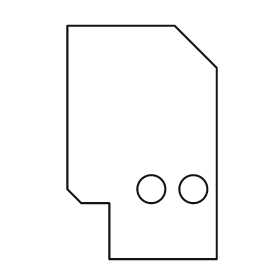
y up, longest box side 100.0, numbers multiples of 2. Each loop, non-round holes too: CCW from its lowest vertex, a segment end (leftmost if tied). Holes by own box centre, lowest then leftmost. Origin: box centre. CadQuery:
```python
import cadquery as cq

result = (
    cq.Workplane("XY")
    .moveTo(-14.0, -50.0)
    .lineTo(32.0, -50.0)
    .lineTo(32.0, 32.0)
    .lineTo(14.0, 50.0)
    .lineTo(-32.0, 50.0)
    .lineTo(-32.0, -20.0)
    .lineTo(-26.0, -26.0)
    .lineTo(-14.0, -26.0)
    .close()
    .moveTo(4.0, -20.0)
    .circle(6.0)
    .moveTo(22.0, -20.0)
    .circle(6.0)
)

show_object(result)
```